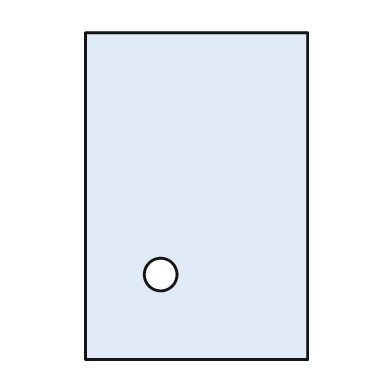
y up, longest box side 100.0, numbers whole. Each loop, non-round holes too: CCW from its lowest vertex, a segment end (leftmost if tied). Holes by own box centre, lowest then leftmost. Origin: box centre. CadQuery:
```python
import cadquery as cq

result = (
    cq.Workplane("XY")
    .moveTo(-34.0, -50.0)
    .lineTo(34.0, -50.0)
    .lineTo(34.0, 50.0)
    .lineTo(-34.0, 50.0)
    .close()
    .moveTo(-11.0, -24.0)
    .circle(5.0)
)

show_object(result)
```